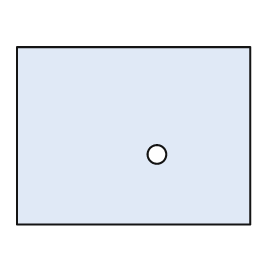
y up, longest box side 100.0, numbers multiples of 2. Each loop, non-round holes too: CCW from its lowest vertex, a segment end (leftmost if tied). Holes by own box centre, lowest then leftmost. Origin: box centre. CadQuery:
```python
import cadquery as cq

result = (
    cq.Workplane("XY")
    .moveTo(-50.0, -38.0)
    .lineTo(50.0, -38.0)
    .lineTo(50.0, 38.0)
    .lineTo(-50.0, 38.0)
    .close()
    .moveTo(10.0, -8.0)
    .circle(4.0)
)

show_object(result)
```